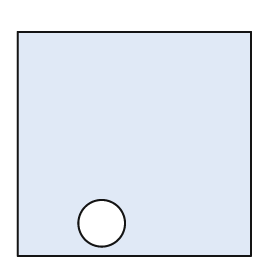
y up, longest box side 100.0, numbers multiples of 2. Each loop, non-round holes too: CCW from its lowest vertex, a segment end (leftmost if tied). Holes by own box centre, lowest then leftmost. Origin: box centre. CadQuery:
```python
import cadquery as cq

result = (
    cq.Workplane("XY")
    .moveTo(-50.0, -48.0)
    .lineTo(50.0, -48.0)
    .lineTo(50.0, 48.0)
    .lineTo(-50.0, 48.0)
    .close()
    .moveTo(-14.0, -34.0)
    .circle(10.0)
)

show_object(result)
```